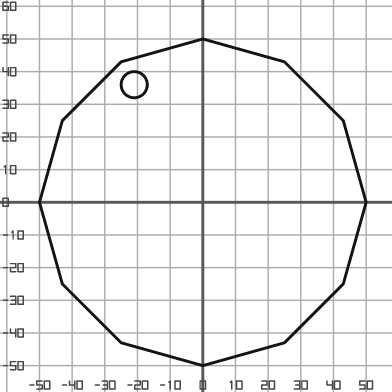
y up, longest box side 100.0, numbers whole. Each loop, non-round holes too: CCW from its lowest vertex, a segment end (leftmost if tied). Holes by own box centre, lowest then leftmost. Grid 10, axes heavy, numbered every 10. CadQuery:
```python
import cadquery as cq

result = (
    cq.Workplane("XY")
    .moveTo(0.0, -50.0)
    .lineTo(25.0, -43.0)
    .lineTo(43.0, -25.0)
    .lineTo(50.0, 0.0)
    .lineTo(43.0, 25.0)
    .lineTo(25.0, 43.0)
    .lineTo(0.0, 50.0)
    .lineTo(-25.0, 43.0)
    .lineTo(-43.0, 25.0)
    .lineTo(-50.0, 0.0)
    .lineTo(-43.0, -25.0)
    .lineTo(-25.0, -43.0)
    .close()
    .moveTo(-21.0, 36.0)
    .circle(4.0)
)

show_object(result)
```